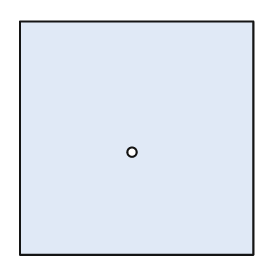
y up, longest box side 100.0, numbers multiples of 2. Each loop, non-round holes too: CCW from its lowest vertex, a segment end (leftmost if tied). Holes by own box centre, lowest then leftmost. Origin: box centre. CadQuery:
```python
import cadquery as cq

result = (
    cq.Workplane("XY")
    .moveTo(-50.0, -50.0)
    .lineTo(50.0, -50.0)
    .lineTo(50.0, 50.0)
    .lineTo(-50.0, 50.0)
    .close()
    .moveTo(-2.0, -6.0)
    .circle(2.0)
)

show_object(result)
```